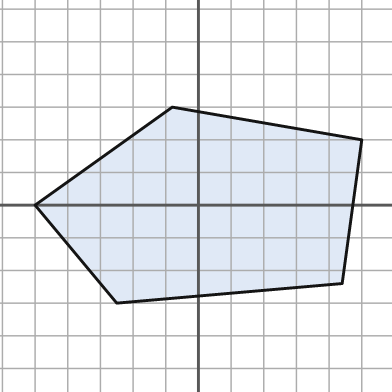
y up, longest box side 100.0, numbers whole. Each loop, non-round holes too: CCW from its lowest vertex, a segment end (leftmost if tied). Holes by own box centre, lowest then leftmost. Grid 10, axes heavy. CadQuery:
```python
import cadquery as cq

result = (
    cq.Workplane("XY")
    .moveTo(-25.0, -30.0)
    .lineTo(44.0, -24.0)
    .lineTo(50.0, 20.0)
    .lineTo(-8.0, 30.0)
    .lineTo(-50.0, 0.0)
    .close()
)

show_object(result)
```